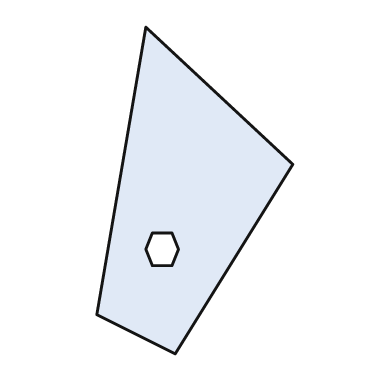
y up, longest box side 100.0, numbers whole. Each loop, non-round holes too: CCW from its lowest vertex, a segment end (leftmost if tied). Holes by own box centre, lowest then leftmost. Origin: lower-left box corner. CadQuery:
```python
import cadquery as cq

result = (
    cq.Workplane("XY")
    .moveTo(24.0, 0.0)
    .lineTo(60.0, 58.0)
    .lineTo(15.0, 100.0)
    .lineTo(0.0, 12.0)
    .close()
    .moveTo(17.0, 27.0)
    .lineTo(23.0, 27.0)
    .lineTo(25.0, 32.0)
    .lineTo(23.0, 37.0)
    .lineTo(17.0, 37.0)
    .lineTo(15.0, 32.0)
    .close()
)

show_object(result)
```